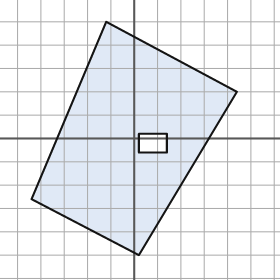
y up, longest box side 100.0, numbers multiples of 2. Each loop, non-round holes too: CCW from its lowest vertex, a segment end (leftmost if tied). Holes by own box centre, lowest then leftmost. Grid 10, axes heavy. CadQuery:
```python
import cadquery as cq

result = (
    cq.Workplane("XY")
    .moveTo(2.0, -50.0)
    .lineTo(44.0, 20.0)
    .lineTo(-12.0, 50.0)
    .lineTo(-44.0, -26.0)
    .close()
    .moveTo(2.0, -6.0)
    .lineTo(14.0, -6.0)
    .lineTo(14.0, 2.0)
    .lineTo(2.0, 2.0)
    .close()
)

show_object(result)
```